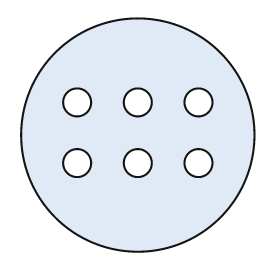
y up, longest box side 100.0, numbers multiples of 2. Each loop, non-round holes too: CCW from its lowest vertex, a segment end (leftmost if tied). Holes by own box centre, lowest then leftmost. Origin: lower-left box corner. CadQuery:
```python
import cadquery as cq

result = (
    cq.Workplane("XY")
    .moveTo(50.0, 50.0)
    .circle(50.0)
    .moveTo(24.0, 38.0)
    .circle(6.0)
    .moveTo(50.0, 38.0)
    .circle(6.0)
    .moveTo(76.0, 38.0)
    .circle(6.0)
    .moveTo(24.0, 64.0)
    .circle(6.0)
    .moveTo(50.0, 64.0)
    .circle(6.0)
    .moveTo(76.0, 64.0)
    .circle(6.0)
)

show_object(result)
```